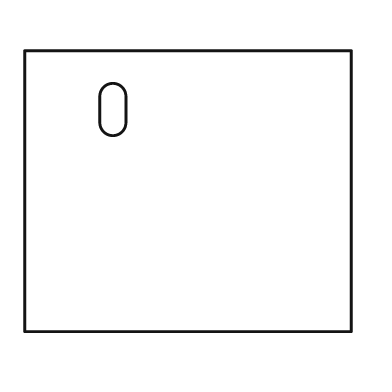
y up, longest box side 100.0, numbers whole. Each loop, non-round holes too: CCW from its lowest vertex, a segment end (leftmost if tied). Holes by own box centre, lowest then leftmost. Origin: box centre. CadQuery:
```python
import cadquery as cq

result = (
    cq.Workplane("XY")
    .moveTo(-50.0, -43.0)
    .lineTo(50.0, -43.0)
    .lineTo(50.0, 43.0)
    .lineTo(-50.0, 43.0)
    .close()
    .moveTo(-27.0, 21.0)
    .threePointArc((-23.0, 17.0), (-19.0, 21.0))
    .lineTo(-19.0, 29.0)
    .threePointArc((-23.0, 33.0), (-27.0, 29.0))
    .close()
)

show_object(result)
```